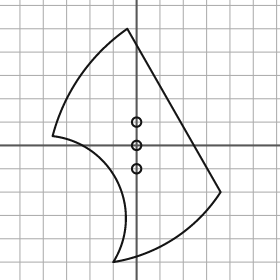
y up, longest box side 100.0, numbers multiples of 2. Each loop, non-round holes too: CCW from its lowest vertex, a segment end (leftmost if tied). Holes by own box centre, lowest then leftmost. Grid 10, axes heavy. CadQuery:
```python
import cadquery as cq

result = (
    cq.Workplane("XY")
    .moveTo(-10.0, -50.0)
    .threePointArc((16.0, -40.0), (36.0, -20.0))
    .lineTo(-4.0, 50.0)
    .threePointArc((-24.0, 30.0), (-36.0, 4.0))
    .threePointArc((-8.0, -16.0), (-10.0, -50.0))
    .close()
    .moveTo(0.0, -10.0)
    .circle(2.0)
    .moveTo(0.0, 0.0)
    .circle(2.0)
    .moveTo(0.0, 10.0)
    .circle(2.0)
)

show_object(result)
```